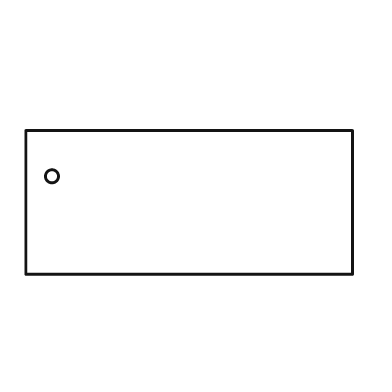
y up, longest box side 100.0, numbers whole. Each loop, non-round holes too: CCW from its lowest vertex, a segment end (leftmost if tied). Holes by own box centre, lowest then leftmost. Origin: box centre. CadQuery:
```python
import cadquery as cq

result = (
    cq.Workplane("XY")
    .moveTo(-50.0, -22.0)
    .lineTo(50.0, -22.0)
    .lineTo(50.0, 22.0)
    .lineTo(-50.0, 22.0)
    .close()
    .moveTo(-42.0, 8.0)
    .circle(2.0)
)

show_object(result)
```